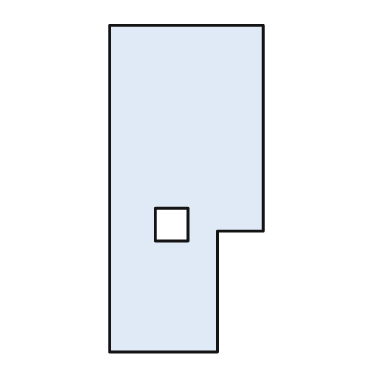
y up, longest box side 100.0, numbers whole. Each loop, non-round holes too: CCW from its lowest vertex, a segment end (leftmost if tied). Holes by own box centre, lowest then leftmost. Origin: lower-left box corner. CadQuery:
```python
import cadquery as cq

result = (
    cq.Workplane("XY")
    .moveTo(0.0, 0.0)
    .lineTo(33.0, 0.0)
    .lineTo(33.0, 37.0)
    .lineTo(47.0, 37.0)
    .lineTo(47.0, 100.0)
    .lineTo(0.0, 100.0)
    .close()
    .moveTo(14.0, 34.0)
    .lineTo(24.0, 34.0)
    .lineTo(24.0, 44.0)
    .lineTo(14.0, 44.0)
    .close()
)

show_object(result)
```